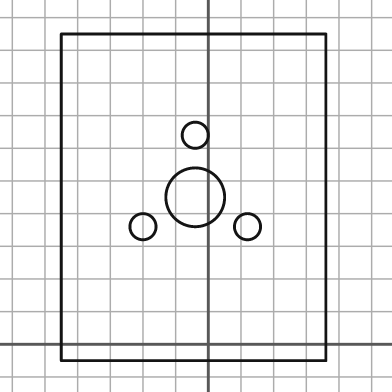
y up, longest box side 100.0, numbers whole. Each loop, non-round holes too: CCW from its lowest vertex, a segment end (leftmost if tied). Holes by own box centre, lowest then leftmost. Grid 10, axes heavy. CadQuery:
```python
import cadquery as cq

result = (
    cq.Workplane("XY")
    .moveTo(-45.0, -5.0)
    .lineTo(36.0, -5.0)
    .lineTo(36.0, 95.0)
    .lineTo(-45.0, 95.0)
    .close()
    .moveTo(-20.0, 36.0)
    .circle(4.0)
    .moveTo(12.0, 36.0)
    .circle(4.0)
    .moveTo(-4.0, 45.0)
    .circle(9.0)
    .moveTo(-4.0, 64.0)
    .circle(4.0)
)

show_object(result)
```